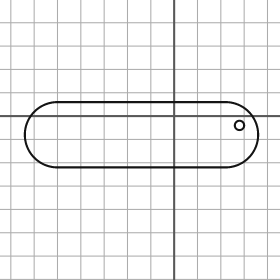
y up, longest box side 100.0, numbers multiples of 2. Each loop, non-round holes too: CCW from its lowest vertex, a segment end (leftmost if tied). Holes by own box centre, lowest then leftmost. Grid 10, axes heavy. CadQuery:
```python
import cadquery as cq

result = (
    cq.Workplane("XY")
    .moveTo(-50.0, -22.0)
    .lineTo(22.0, -22.0)
    .threePointArc((36.0, -8.0), (22.0, 6.0))
    .lineTo(-50.0, 6.0)
    .threePointArc((-64.0, -8.0), (-50.0, -22.0))
    .close()
    .moveTo(28.0, -4.0)
    .circle(2.0)
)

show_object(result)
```